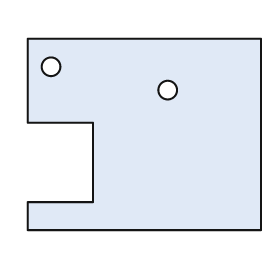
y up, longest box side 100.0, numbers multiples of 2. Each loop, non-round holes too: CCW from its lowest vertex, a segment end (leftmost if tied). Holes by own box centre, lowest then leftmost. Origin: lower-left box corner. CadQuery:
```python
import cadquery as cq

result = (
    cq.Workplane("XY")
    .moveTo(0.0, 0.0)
    .lineTo(100.0, 0.0)
    .lineTo(100.0, 82.0)
    .lineTo(0.0, 82.0)
    .lineTo(0.0, 46.0)
    .lineTo(28.0, 46.0)
    .lineTo(28.0, 12.0)
    .lineTo(0.0, 12.0)
    .close()
    .moveTo(60.0, 60.0)
    .circle(4.0)
    .moveTo(10.0, 70.0)
    .circle(4.0)
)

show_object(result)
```